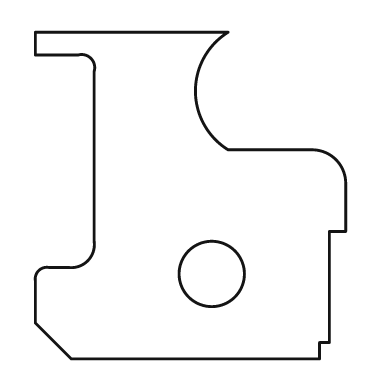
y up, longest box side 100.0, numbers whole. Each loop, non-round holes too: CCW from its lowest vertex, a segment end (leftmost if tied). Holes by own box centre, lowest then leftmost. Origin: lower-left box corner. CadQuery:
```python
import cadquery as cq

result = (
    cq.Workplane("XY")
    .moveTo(11.0, 0.0)
    .lineTo(87.0, 0.0)
    .lineTo(87.0, 5.0)
    .lineTo(90.0, 5.0)
    .lineTo(90.0, 39.0)
    .lineTo(95.0, 39.0)
    .lineTo(95.0, 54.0)
    .threePointArc((92.0, 61.0), (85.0, 64.0))
    .lineTo(59.0, 64.0)
    .threePointArc((49.0, 82.0), (59.0, 100.0))
    .lineTo(0.0, 100.0)
    .lineTo(0.0, 93.0)
    .lineTo(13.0, 93.0)
    .threePointArc((17.0, 92.0), (18.0, 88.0))
    .lineTo(18.0, 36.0)
    .threePointArc((16.0, 30.0), (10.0, 28.0))
    .lineTo(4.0, 28.0)
    .threePointArc((1.0, 27.0), (0.0, 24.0))
    .lineTo(0.0, 11.0)
    .close()
    .moveTo(54.0, 26.0)
    .circle(10.0)
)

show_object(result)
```